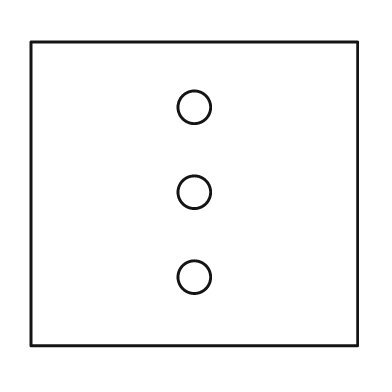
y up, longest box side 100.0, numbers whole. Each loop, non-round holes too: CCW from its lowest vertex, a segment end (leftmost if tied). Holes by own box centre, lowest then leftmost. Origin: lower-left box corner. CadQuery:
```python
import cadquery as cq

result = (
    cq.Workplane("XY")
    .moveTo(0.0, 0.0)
    .lineTo(100.0, 0.0)
    .lineTo(100.0, 93.0)
    .lineTo(0.0, 93.0)
    .close()
    .moveTo(50.0, 21.0)
    .circle(5.0)
    .moveTo(50.0, 47.0)
    .circle(5.0)
    .moveTo(50.0, 73.0)
    .circle(5.0)
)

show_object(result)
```